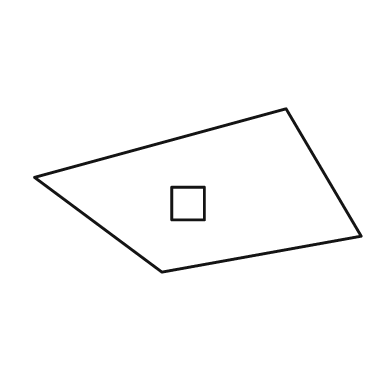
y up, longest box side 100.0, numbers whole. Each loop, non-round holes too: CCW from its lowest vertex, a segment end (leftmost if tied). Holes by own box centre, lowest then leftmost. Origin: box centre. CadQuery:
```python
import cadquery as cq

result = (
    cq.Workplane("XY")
    .moveTo(-11.0, -25.0)
    .lineTo(50.0, -14.0)
    .lineTo(27.0, 25.0)
    .lineTo(-50.0, 4.0)
    .close()
    .moveTo(-8.0, -9.0)
    .lineTo(2.0, -9.0)
    .lineTo(2.0, 1.0)
    .lineTo(-8.0, 1.0)
    .close()
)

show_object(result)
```